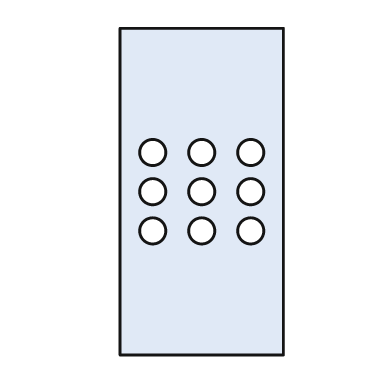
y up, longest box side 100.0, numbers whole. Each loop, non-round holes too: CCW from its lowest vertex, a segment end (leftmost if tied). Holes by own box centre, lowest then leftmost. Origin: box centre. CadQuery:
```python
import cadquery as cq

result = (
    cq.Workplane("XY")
    .moveTo(-25.0, -50.0)
    .lineTo(25.0, -50.0)
    .lineTo(25.0, 50.0)
    .lineTo(-25.0, 50.0)
    .close()
    .moveTo(-15.0, -12.0)
    .circle(4.0)
    .moveTo(0.0, -12.0)
    .circle(4.0)
    .moveTo(15.0, -12.0)
    .circle(4.0)
    .moveTo(-15.0, 0.0)
    .circle(4.0)
    .moveTo(0.0, 0.0)
    .circle(4.0)
    .moveTo(15.0, 0.0)
    .circle(4.0)
    .moveTo(-15.0, 12.0)
    .circle(4.0)
    .moveTo(0.0, 12.0)
    .circle(4.0)
    .moveTo(15.0, 12.0)
    .circle(4.0)
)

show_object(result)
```